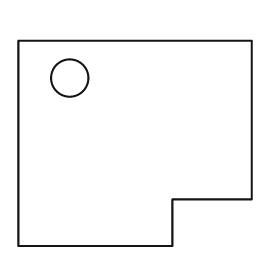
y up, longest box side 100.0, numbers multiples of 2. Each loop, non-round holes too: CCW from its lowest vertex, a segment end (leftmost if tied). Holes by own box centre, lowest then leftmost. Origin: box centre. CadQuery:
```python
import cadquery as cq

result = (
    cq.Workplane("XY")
    .moveTo(-50.0, -44.0)
    .lineTo(16.0, -44.0)
    .lineTo(16.0, -24.0)
    .lineTo(50.0, -24.0)
    .lineTo(50.0, 44.0)
    .lineTo(-50.0, 44.0)
    .close()
    .moveTo(-28.0, 28.0)
    .circle(8.0)
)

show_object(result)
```